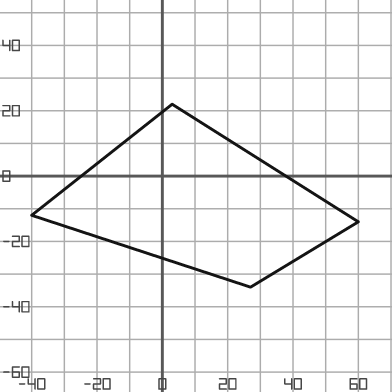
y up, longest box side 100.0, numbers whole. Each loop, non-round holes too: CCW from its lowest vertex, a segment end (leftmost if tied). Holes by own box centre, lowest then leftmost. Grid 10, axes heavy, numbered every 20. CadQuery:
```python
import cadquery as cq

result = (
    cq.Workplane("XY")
    .moveTo(27.0, -34.0)
    .lineTo(60.0, -14.0)
    .lineTo(3.0, 22.0)
    .lineTo(-40.0, -12.0)
    .close()
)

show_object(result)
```